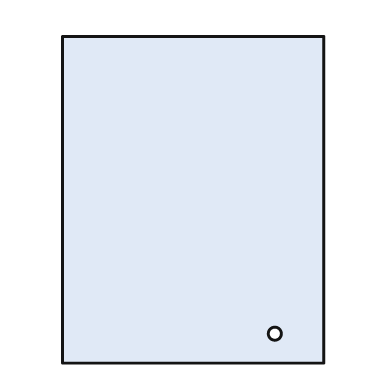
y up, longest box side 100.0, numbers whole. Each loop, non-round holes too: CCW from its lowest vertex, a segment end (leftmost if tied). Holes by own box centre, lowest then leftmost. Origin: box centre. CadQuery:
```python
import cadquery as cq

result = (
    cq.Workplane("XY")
    .moveTo(-40.0, -50.0)
    .lineTo(40.0, -50.0)
    .lineTo(40.0, 50.0)
    .lineTo(-40.0, 50.0)
    .close()
    .moveTo(25.0, -41.0)
    .circle(2.0)
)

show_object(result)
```